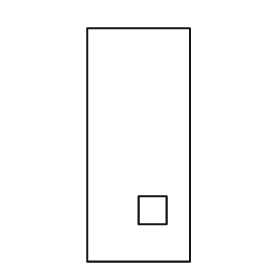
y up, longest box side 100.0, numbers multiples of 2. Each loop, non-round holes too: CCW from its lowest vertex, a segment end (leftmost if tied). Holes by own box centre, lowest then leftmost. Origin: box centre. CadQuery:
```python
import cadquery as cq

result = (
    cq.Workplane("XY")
    .moveTo(-22.0, -50.0)
    .lineTo(22.0, -50.0)
    .lineTo(22.0, 50.0)
    .lineTo(-22.0, 50.0)
    .close()
    .moveTo(0.0, -34.0)
    .lineTo(12.0, -34.0)
    .lineTo(12.0, -22.0)
    .lineTo(0.0, -22.0)
    .close()
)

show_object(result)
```